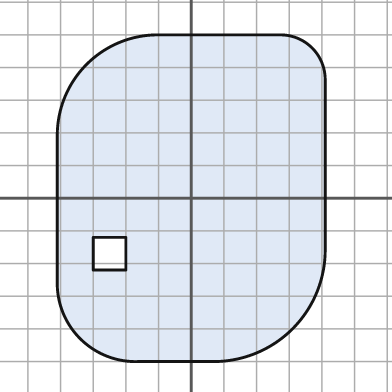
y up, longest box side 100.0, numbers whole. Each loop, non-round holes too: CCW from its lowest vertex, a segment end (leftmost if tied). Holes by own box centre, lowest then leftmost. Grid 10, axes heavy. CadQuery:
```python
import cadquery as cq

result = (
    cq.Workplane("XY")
    .moveTo(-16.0, -50.0)
    .lineTo(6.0, -50.0)
    .threePointArc((31.0, -40.0), (41.0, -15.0))
    .lineTo(41.0, 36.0)
    .threePointArc((37.0, 46.0), (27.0, 50.0))
    .lineTo(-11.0, 50.0)
    .threePointArc((-32.0, 41.0), (-41.0, 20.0))
    .lineTo(-41.0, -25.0)
    .threePointArc((-34.0, -43.0), (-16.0, -50.0))
    .close()
    .moveTo(-30.0, -22.0)
    .lineTo(-20.0, -22.0)
    .lineTo(-20.0, -12.0)
    .lineTo(-30.0, -12.0)
    .close()
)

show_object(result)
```